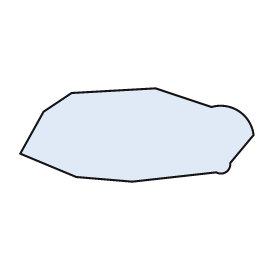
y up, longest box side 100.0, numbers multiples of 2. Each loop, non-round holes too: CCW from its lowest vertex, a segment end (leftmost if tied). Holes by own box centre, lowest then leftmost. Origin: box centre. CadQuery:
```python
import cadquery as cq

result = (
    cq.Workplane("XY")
    .moveTo(-2.0, -20.0)
    .lineTo(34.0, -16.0)
    .threePointArc((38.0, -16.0), (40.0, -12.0))
    .lineTo(50.0, 0.0)
    .threePointArc((44.0, 10.0), (32.0, 12.0))
    .lineTo(8.0, 20.0)
    .lineTo(-28.0, 18.0)
    .lineTo(-40.0, 10.0)
    .lineTo(-50.0, -8.0)
    .lineTo(-26.0, -18.0)
    .close()
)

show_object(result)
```